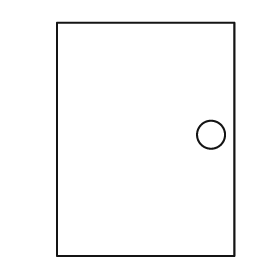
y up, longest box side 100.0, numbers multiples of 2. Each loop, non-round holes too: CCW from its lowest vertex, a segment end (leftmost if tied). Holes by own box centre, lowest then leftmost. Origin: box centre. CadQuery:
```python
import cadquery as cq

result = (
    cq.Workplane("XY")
    .moveTo(-38.0, -50.0)
    .lineTo(38.0, -50.0)
    .lineTo(38.0, 50.0)
    .lineTo(-38.0, 50.0)
    .close()
    .moveTo(28.0, 2.0)
    .circle(6.0)
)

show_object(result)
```